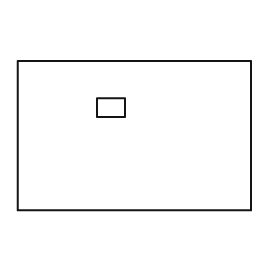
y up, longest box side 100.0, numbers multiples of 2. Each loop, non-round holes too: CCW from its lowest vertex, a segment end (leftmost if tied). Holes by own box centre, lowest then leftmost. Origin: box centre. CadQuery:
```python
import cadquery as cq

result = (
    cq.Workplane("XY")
    .moveTo(-50.0, -32.0)
    .lineTo(50.0, -32.0)
    .lineTo(50.0, 32.0)
    .lineTo(-50.0, 32.0)
    .close()
    .moveTo(-16.0, 8.0)
    .lineTo(-4.0, 8.0)
    .lineTo(-4.0, 16.0)
    .lineTo(-16.0, 16.0)
    .close()
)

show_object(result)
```